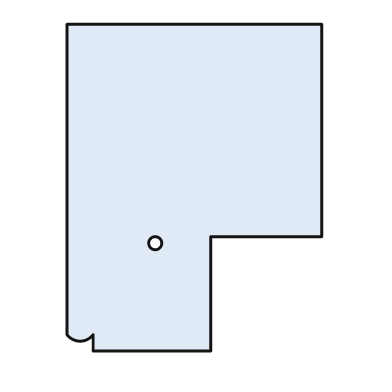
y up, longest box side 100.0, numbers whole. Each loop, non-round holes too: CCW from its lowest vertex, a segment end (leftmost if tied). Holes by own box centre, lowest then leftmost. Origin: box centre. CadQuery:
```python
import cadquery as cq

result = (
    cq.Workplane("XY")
    .moveTo(-31.0, -50.0)
    .lineTo(5.0, -50.0)
    .lineTo(5.0, -15.0)
    .lineTo(39.0, -15.0)
    .lineTo(39.0, 50.0)
    .lineTo(-39.0, 50.0)
    .lineTo(-39.0, -45.0)
    .threePointArc((-35.0, -47.0), (-31.0, -45.0))
    .close()
    .moveTo(-12.0, -17.0)
    .circle(2.0)
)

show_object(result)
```